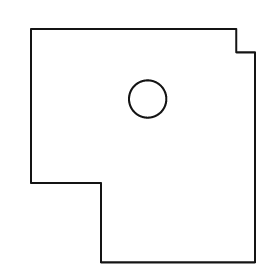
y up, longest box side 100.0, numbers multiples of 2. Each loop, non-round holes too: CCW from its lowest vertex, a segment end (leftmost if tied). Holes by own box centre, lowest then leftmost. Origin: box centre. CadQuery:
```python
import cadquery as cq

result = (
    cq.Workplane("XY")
    .moveTo(-18.0, -50.0)
    .lineTo(48.0, -50.0)
    .lineTo(48.0, 40.0)
    .lineTo(40.0, 40.0)
    .lineTo(40.0, 50.0)
    .lineTo(-48.0, 50.0)
    .lineTo(-48.0, -16.0)
    .lineTo(-18.0, -16.0)
    .close()
    .moveTo(2.0, 20.0)
    .circle(8.0)
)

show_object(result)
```